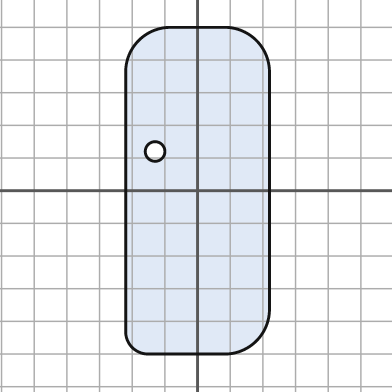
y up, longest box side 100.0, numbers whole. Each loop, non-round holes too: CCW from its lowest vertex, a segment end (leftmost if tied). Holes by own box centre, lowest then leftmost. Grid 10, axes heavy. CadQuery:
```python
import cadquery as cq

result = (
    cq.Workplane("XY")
    .moveTo(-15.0, -50.0)
    .lineTo(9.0, -50.0)
    .threePointArc((18.0, -46.0), (22.0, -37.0))
    .lineTo(22.0, 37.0)
    .threePointArc((18.0, 46.0), (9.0, 50.0))
    .lineTo(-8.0, 50.0)
    .threePointArc((-18.0, 46.0), (-22.0, 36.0))
    .lineTo(-22.0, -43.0)
    .threePointArc((-20.0, -48.0), (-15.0, -50.0))
    .close()
    .moveTo(-13.0, 12.0)
    .circle(3.0)
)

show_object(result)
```